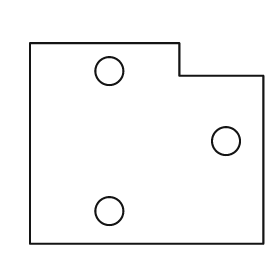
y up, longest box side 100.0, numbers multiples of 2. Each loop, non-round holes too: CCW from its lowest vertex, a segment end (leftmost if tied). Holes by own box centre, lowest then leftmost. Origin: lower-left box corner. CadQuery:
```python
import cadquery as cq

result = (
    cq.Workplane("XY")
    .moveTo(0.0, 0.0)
    .lineTo(100.0, 0.0)
    .lineTo(100.0, 72.0)
    .lineTo(64.0, 72.0)
    .lineTo(64.0, 86.0)
    .lineTo(0.0, 86.0)
    .close()
    .moveTo(34.0, 14.0)
    .circle(6.0)
    .moveTo(84.0, 44.0)
    .circle(6.0)
    .moveTo(34.0, 74.0)
    .circle(6.0)
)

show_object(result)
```